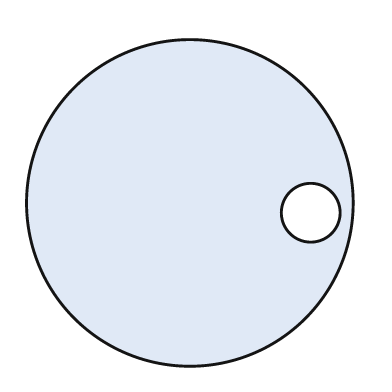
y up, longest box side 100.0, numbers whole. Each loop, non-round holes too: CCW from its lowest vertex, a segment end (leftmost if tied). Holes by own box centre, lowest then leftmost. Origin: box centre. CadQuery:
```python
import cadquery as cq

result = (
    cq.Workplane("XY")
    .moveTo(0.0, 0.0)
    .circle(50.0)
    .moveTo(37.0, -3.0)
    .circle(9.0)
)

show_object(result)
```